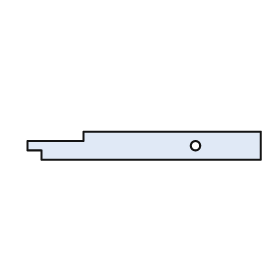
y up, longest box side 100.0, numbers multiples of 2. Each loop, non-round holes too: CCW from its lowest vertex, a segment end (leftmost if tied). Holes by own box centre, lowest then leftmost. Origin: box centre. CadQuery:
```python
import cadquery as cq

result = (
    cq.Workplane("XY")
    .moveTo(-44.0, -6.0)
    .lineTo(50.0, -6.0)
    .lineTo(50.0, 6.0)
    .lineTo(-26.0, 6.0)
    .lineTo(-26.0, 2.0)
    .lineTo(-50.0, 2.0)
    .lineTo(-50.0, -2.0)
    .lineTo(-44.0, -2.0)
    .close()
    .moveTo(22.0, 0.0)
    .circle(2.0)
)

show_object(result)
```